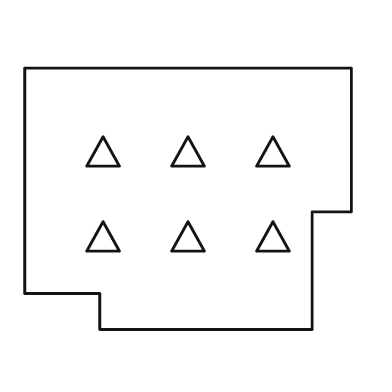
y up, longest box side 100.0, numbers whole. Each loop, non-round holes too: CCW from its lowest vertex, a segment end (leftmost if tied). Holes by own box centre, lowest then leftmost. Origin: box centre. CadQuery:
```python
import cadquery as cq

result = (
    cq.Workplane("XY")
    .moveTo(-27.0, -40.0)
    .lineTo(38.0, -40.0)
    .lineTo(38.0, -4.0)
    .lineTo(50.0, -4.0)
    .lineTo(50.0, 40.0)
    .lineTo(-50.0, 40.0)
    .lineTo(-50.0, -29.0)
    .lineTo(-27.0, -29.0)
    .close()
    .moveTo(-31.0, -16.0)
    .lineTo(-21.0, -16.0)
    .lineTo(-26.0, -7.0)
    .close()
    .moveTo(-5.0, -16.0)
    .lineTo(5.0, -16.0)
    .lineTo(0.0, -7.0)
    .close()
    .moveTo(21.0, -16.0)
    .lineTo(31.0, -16.0)
    .lineTo(26.0, -7.0)
    .close()
    .moveTo(-31.0, 10.0)
    .lineTo(-21.0, 10.0)
    .lineTo(-26.0, 19.0)
    .close()
    .moveTo(-5.0, 10.0)
    .lineTo(5.0, 10.0)
    .lineTo(0.0, 19.0)
    .close()
    .moveTo(21.0, 10.0)
    .lineTo(31.0, 10.0)
    .lineTo(26.0, 19.0)
    .close()
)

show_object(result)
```